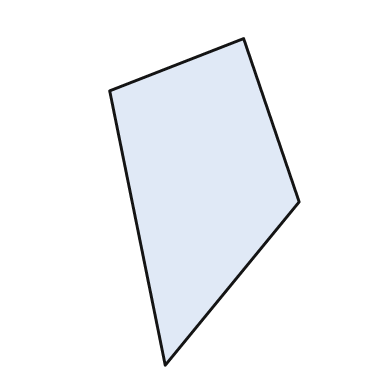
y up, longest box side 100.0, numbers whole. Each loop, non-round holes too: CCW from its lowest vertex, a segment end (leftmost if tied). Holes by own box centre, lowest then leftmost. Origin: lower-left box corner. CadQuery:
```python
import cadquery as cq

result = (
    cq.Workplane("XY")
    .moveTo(17.0, 0.0)
    .lineTo(58.0, 50.0)
    .lineTo(41.0, 100.0)
    .lineTo(0.0, 84.0)
    .close()
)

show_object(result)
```